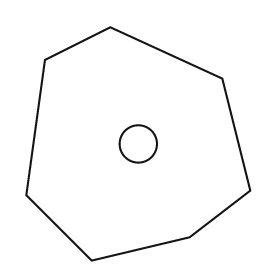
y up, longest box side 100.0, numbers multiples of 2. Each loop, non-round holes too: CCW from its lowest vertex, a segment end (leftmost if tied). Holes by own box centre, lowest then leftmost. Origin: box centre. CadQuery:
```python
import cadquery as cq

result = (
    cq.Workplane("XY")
    .moveTo(-20.0, -50.0)
    .lineTo(22.0, -40.0)
    .lineTo(48.0, -20.0)
    .lineTo(36.0, 28.0)
    .lineTo(-12.0, 50.0)
    .lineTo(-40.0, 36.0)
    .lineTo(-48.0, -22.0)
    .close()
    .moveTo(0.0, 0.0)
    .circle(8.0)
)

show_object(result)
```